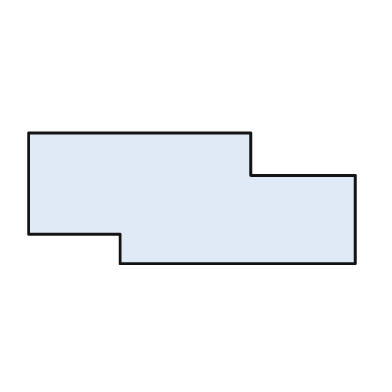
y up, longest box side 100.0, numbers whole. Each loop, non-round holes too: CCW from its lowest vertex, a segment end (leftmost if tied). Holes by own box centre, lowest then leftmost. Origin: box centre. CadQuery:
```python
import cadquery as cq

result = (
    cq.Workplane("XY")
    .moveTo(-22.0, -20.0)
    .lineTo(50.0, -20.0)
    .lineTo(50.0, 7.0)
    .lineTo(18.0, 7.0)
    .lineTo(18.0, 20.0)
    .lineTo(-50.0, 20.0)
    .lineTo(-50.0, -11.0)
    .lineTo(-22.0, -11.0)
    .close()
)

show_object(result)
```